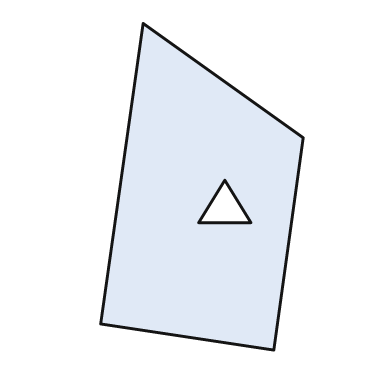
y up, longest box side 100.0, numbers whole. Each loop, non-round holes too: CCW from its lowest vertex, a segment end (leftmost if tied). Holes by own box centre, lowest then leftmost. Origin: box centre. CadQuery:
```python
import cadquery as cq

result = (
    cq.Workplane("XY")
    .moveTo(22.0, -50.0)
    .lineTo(31.0, 15.0)
    .lineTo(-18.0, 50.0)
    .lineTo(-31.0, -42.0)
    .close()
    .moveTo(-1.0, -11.0)
    .lineTo(15.0, -11.0)
    .lineTo(7.0, 2.0)
    .close()
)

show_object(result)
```